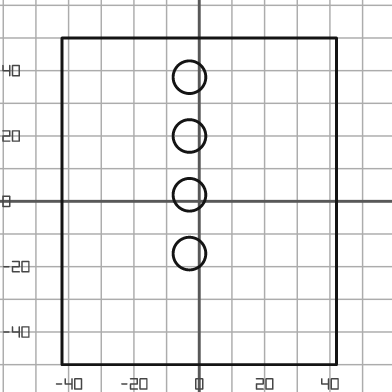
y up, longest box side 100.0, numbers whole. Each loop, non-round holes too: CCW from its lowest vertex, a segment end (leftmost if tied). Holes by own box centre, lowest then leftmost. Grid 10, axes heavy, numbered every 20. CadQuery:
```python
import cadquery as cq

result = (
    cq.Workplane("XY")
    .moveTo(-42.0, -50.0)
    .lineTo(42.0, -50.0)
    .lineTo(42.0, 50.0)
    .lineTo(-42.0, 50.0)
    .close()
    .moveTo(-3.0, -16.0)
    .circle(5.0)
    .moveTo(-3.0, 2.0)
    .circle(5.0)
    .moveTo(-3.0, 20.0)
    .circle(5.0)
    .moveTo(-3.0, 38.0)
    .circle(5.0)
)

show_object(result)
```